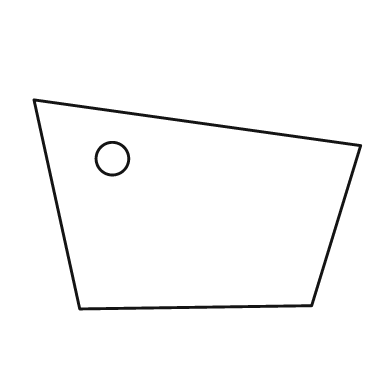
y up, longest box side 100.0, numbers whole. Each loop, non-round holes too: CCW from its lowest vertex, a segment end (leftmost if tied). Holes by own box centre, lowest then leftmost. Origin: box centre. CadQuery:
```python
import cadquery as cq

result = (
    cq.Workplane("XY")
    .moveTo(-36.0, -32.0)
    .lineTo(35.0, -31.0)
    .lineTo(50.0, 18.0)
    .lineTo(-50.0, 32.0)
    .close()
    .moveTo(-26.0, 14.0)
    .circle(5.0)
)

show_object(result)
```